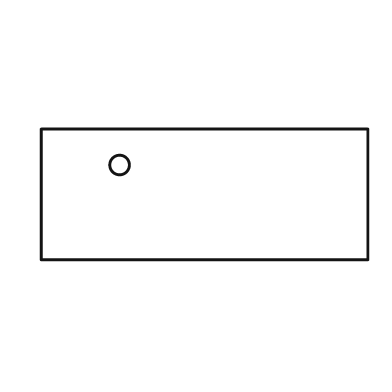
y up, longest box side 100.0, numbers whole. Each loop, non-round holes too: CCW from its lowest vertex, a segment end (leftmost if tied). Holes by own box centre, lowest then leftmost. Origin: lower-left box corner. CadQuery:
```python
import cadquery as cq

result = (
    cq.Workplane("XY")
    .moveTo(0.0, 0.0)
    .lineTo(100.0, 0.0)
    .lineTo(100.0, 40.0)
    .lineTo(0.0, 40.0)
    .close()
    .moveTo(24.0, 29.0)
    .circle(3.0)
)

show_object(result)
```